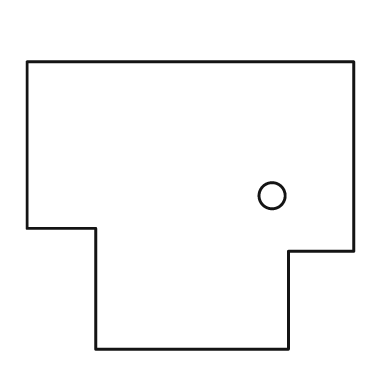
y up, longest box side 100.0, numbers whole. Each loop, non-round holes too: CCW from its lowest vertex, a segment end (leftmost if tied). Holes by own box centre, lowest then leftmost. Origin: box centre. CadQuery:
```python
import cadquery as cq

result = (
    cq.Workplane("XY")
    .moveTo(-29.0, -44.0)
    .lineTo(30.0, -44.0)
    .lineTo(30.0, -14.0)
    .lineTo(50.0, -14.0)
    .lineTo(50.0, 44.0)
    .lineTo(-50.0, 44.0)
    .lineTo(-50.0, -7.0)
    .lineTo(-29.0, -7.0)
    .close()
    .moveTo(25.0, 3.0)
    .circle(4.0)
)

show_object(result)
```